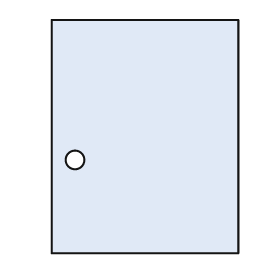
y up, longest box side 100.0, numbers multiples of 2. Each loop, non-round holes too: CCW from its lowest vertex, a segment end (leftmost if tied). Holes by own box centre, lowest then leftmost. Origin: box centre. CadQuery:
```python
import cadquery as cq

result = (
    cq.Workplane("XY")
    .moveTo(-40.0, -50.0)
    .lineTo(40.0, -50.0)
    .lineTo(40.0, 50.0)
    .lineTo(-40.0, 50.0)
    .close()
    .moveTo(-30.0, -10.0)
    .circle(4.0)
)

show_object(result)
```